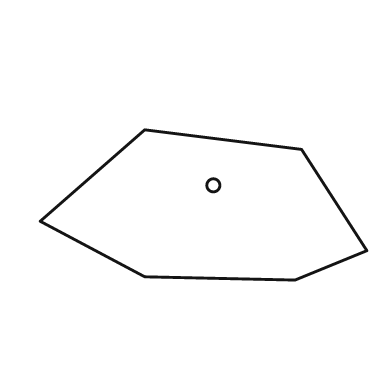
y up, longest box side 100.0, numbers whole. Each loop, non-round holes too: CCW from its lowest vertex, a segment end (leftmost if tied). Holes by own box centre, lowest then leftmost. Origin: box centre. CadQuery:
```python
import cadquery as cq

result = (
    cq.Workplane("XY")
    .moveTo(28.0, -23.0)
    .lineTo(50.0, -14.0)
    .lineTo(30.0, 17.0)
    .lineTo(-18.0, 23.0)
    .lineTo(-50.0, -5.0)
    .lineTo(-18.0, -22.0)
    .close()
    .moveTo(3.0, 6.0)
    .circle(2.0)
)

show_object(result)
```